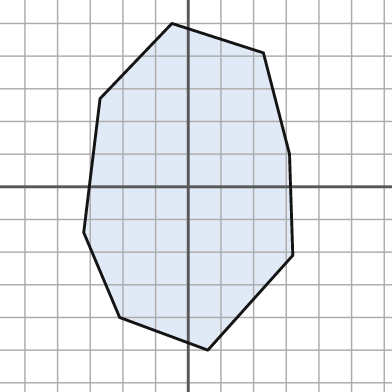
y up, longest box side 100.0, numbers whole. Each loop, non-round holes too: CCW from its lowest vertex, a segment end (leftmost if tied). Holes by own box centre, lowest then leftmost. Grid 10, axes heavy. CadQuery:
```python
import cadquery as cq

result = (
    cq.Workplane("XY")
    .moveTo(6.0, -50.0)
    .lineTo(32.0, -21.0)
    .lineTo(31.0, 10.0)
    .lineTo(23.0, 41.0)
    .lineTo(-5.0, 50.0)
    .lineTo(-27.0, 27.0)
    .lineTo(-32.0, -14.0)
    .lineTo(-21.0, -40.0)
    .close()
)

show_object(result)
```